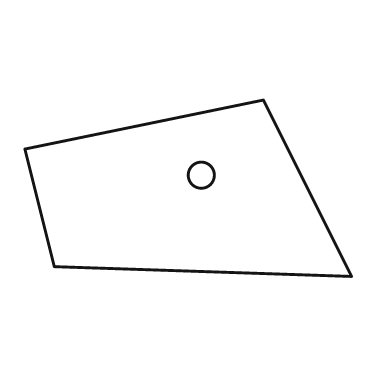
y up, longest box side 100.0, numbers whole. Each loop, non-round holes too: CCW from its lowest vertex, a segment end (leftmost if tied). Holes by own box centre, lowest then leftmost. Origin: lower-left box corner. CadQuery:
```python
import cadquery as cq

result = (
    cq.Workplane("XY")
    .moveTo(100.0, 0.0)
    .lineTo(73.0, 54.0)
    .lineTo(0.0, 39.0)
    .lineTo(9.0, 3.0)
    .close()
    .moveTo(54.0, 31.0)
    .circle(4.0)
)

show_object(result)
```